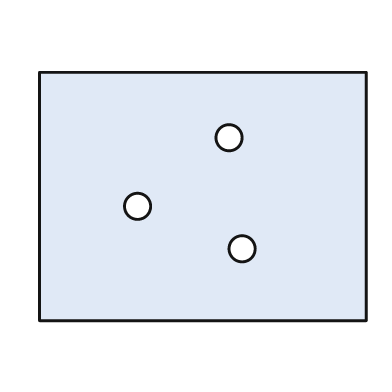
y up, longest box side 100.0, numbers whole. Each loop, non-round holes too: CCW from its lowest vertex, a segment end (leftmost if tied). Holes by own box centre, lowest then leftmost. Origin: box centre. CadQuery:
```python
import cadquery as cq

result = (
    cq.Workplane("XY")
    .moveTo(-50.0, -38.0)
    .lineTo(50.0, -38.0)
    .lineTo(50.0, 38.0)
    .lineTo(-50.0, 38.0)
    .close()
    .moveTo(12.0, -16.0)
    .circle(4.0)
    .moveTo(-20.0, -3.0)
    .circle(4.0)
    .moveTo(8.0, 18.0)
    .circle(4.0)
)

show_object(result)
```